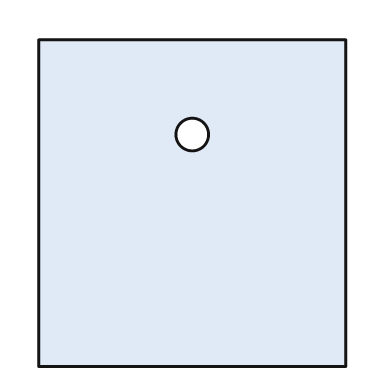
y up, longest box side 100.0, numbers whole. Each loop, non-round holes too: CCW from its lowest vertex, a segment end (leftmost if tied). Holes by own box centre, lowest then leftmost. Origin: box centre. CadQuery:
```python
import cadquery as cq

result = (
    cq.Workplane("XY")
    .moveTo(-47.0, -50.0)
    .lineTo(47.0, -50.0)
    .lineTo(47.0, 50.0)
    .lineTo(-47.0, 50.0)
    .close()
    .moveTo(0.0, 21.0)
    .circle(5.0)
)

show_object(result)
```